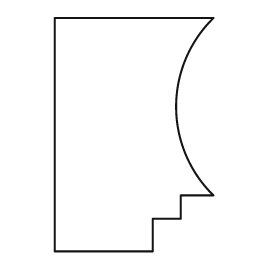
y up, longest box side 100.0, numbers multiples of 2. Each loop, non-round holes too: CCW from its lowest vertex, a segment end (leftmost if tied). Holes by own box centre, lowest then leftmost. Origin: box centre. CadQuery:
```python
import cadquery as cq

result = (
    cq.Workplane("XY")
    .moveTo(-34.0, -50.0)
    .lineTo(8.0, -50.0)
    .lineTo(8.0, -36.0)
    .lineTo(20.0, -36.0)
    .lineTo(20.0, -26.0)
    .lineTo(34.0, -26.0)
    .threePointArc((18.0, 12.0), (34.0, 50.0))
    .lineTo(-34.0, 50.0)
    .close()
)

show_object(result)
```